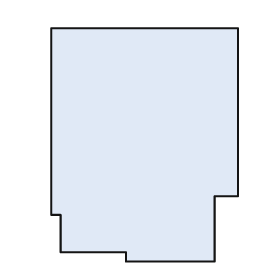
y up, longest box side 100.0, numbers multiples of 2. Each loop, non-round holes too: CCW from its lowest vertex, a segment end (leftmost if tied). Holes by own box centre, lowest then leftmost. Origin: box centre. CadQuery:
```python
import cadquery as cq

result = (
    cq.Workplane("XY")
    .moveTo(-8.0, -50.0)
    .lineTo(30.0, -50.0)
    .lineTo(30.0, -22.0)
    .lineTo(40.0, -22.0)
    .lineTo(40.0, 50.0)
    .lineTo(-40.0, 50.0)
    .lineTo(-40.0, -30.0)
    .lineTo(-36.0, -30.0)
    .lineTo(-36.0, -46.0)
    .lineTo(-8.0, -46.0)
    .close()
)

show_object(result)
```